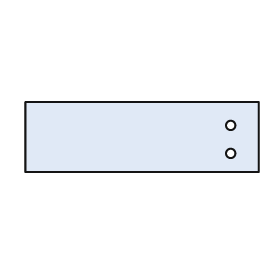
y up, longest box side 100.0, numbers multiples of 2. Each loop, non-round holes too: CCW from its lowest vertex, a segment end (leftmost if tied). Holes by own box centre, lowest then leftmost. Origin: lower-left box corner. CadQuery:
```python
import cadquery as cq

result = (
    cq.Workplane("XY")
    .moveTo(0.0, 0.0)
    .lineTo(100.0, 0.0)
    .lineTo(100.0, 30.0)
    .lineTo(0.0, 30.0)
    .close()
    .moveTo(88.0, 8.0)
    .circle(2.0)
    .moveTo(88.0, 20.0)
    .circle(2.0)
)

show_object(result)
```